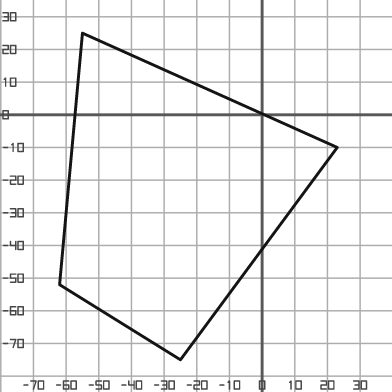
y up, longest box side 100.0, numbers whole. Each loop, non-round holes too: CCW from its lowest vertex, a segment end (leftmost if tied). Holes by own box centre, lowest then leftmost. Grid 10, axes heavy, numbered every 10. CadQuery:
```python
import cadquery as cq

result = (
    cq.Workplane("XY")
    .moveTo(-25.0, -75.0)
    .lineTo(23.0, -10.0)
    .lineTo(-55.0, 25.0)
    .lineTo(-62.0, -52.0)
    .close()
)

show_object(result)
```